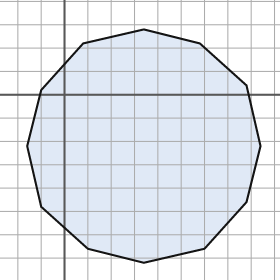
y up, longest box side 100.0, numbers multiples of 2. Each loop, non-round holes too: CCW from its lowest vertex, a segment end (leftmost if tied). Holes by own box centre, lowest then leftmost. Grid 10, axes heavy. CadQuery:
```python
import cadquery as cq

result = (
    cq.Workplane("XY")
    .moveTo(34.0, -72.0)
    .lineTo(60.0, -66.0)
    .lineTo(78.0, -46.0)
    .lineTo(84.0, -22.0)
    .lineTo(78.0, 4.0)
    .lineTo(58.0, 22.0)
    .lineTo(34.0, 28.0)
    .lineTo(8.0, 22.0)
    .lineTo(-10.0, 2.0)
    .lineTo(-16.0, -22.0)
    .lineTo(-10.0, -48.0)
    .lineTo(10.0, -66.0)
    .close()
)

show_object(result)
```